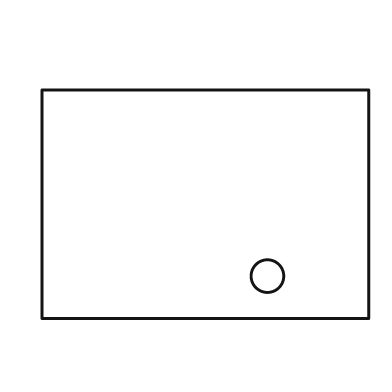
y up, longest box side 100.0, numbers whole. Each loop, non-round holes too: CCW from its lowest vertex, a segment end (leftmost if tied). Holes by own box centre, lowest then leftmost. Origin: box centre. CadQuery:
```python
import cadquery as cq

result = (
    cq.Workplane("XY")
    .moveTo(-50.0, -35.0)
    .lineTo(50.0, -35.0)
    .lineTo(50.0, 35.0)
    .lineTo(-50.0, 35.0)
    .close()
    .moveTo(19.0, -22.0)
    .circle(5.0)
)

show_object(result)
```